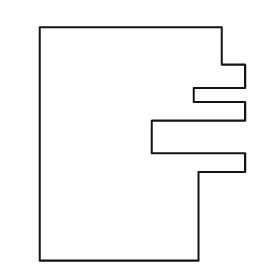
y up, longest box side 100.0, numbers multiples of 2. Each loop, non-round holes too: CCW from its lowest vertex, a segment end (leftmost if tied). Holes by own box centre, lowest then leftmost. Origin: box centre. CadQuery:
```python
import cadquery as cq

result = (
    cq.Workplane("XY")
    .moveTo(-44.0, -50.0)
    .lineTo(24.0, -50.0)
    .lineTo(24.0, -12.0)
    .lineTo(44.0, -12.0)
    .lineTo(44.0, -4.0)
    .lineTo(4.0, -4.0)
    .lineTo(4.0, 10.0)
    .lineTo(44.0, 10.0)
    .lineTo(44.0, 18.0)
    .lineTo(22.0, 18.0)
    .lineTo(22.0, 24.0)
    .lineTo(44.0, 24.0)
    .lineTo(44.0, 34.0)
    .lineTo(34.0, 34.0)
    .lineTo(34.0, 50.0)
    .lineTo(-44.0, 50.0)
    .close()
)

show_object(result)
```